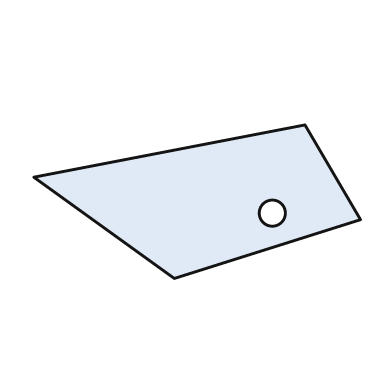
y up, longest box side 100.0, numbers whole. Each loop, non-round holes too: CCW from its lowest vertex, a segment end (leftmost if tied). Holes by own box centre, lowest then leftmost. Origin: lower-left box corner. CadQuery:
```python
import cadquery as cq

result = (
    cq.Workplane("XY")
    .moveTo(43.0, 0.0)
    .lineTo(100.0, 18.0)
    .lineTo(83.0, 47.0)
    .lineTo(0.0, 31.0)
    .close()
    .moveTo(73.0, 20.0)
    .circle(4.0)
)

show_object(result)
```